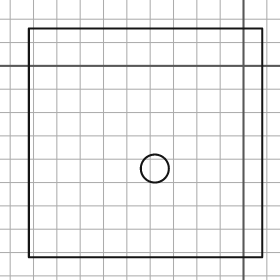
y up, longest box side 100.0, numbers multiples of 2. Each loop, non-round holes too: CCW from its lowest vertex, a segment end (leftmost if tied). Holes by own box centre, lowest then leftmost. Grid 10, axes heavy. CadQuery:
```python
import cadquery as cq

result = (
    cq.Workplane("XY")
    .moveTo(-92.0, -82.0)
    .lineTo(8.0, -82.0)
    .lineTo(8.0, 16.0)
    .lineTo(-92.0, 16.0)
    .close()
    .moveTo(-38.0, -44.0)
    .circle(6.0)
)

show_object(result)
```